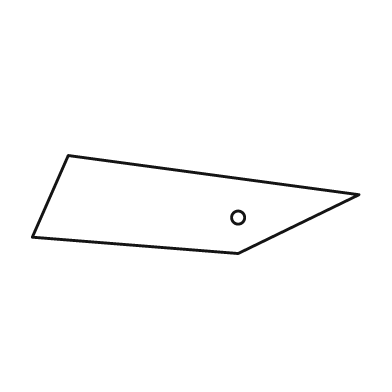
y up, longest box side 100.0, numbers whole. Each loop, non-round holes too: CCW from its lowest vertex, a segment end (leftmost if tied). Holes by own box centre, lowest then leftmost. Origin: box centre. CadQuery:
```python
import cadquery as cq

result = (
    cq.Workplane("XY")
    .moveTo(13.0, -15.0)
    .lineTo(50.0, 3.0)
    .lineTo(-39.0, 15.0)
    .lineTo(-50.0, -10.0)
    .close()
    .moveTo(13.0, -4.0)
    .circle(2.0)
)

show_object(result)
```